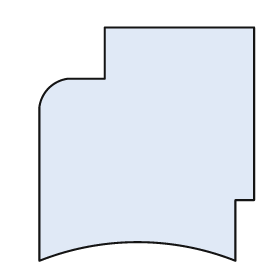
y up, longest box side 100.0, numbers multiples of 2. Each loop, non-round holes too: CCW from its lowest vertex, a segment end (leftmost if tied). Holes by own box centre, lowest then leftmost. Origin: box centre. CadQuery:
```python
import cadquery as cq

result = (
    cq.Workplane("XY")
    .moveTo(-46.0, -50.0)
    .threePointArc((-4.0, -42.0), (38.0, -50.0))
    .lineTo(38.0, -24.0)
    .lineTo(46.0, -24.0)
    .lineTo(46.0, 50.0)
    .lineTo(-18.0, 50.0)
    .lineTo(-18.0, 28.0)
    .lineTo(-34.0, 28.0)
    .threePointArc((-42.0, 24.0), (-46.0, 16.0))
    .close()
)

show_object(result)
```